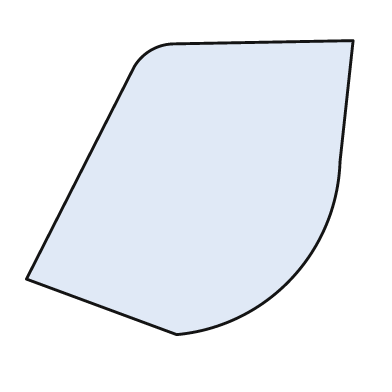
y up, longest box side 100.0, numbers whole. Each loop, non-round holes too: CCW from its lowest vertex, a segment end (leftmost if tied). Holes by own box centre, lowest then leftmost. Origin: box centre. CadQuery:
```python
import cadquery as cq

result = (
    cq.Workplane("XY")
    .moveTo(-4.0, -45.0)
    .threePointArc((31.0, -28.0), (46.0, 8.0))
    .lineTo(50.0, 45.0)
    .lineTo(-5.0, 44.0)
    .threePointArc((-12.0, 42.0), (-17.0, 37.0))
    .lineTo(-50.0, -28.0)
    .close()
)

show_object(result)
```